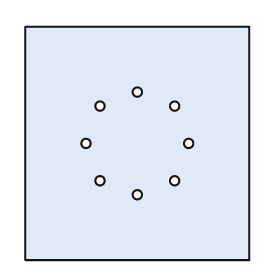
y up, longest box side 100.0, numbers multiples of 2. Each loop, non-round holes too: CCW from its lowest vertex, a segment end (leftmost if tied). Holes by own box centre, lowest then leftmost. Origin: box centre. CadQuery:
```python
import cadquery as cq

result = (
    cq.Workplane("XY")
    .moveTo(-48.0, -50.0)
    .lineTo(48.0, -50.0)
    .lineTo(48.0, 50.0)
    .lineTo(-48.0, 50.0)
    .close()
    .moveTo(0.0, -22.0)
    .circle(2.0)
    .moveTo(-16.0, -16.0)
    .circle(2.0)
    .moveTo(16.0, -16.0)
    .circle(2.0)
    .moveTo(-22.0, 0.0)
    .circle(2.0)
    .moveTo(22.0, 0.0)
    .circle(2.0)
    .moveTo(-16.0, 16.0)
    .circle(2.0)
    .moveTo(16.0, 16.0)
    .circle(2.0)
    .moveTo(0.0, 22.0)
    .circle(2.0)
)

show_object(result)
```